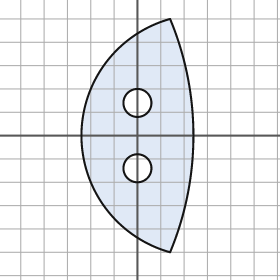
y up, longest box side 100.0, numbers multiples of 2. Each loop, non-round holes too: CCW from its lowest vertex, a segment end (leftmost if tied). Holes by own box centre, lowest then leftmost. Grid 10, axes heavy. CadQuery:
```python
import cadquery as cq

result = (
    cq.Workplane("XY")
    .moveTo(14.0, -50.0)
    .threePointArc((24.0, 0.0), (14.0, 50.0))
    .threePointArc((-24.0, 0.0), (14.0, -50.0))
    .close()
    .moveTo(0.0, -14.0)
    .circle(6.0)
    .moveTo(0.0, 14.0)
    .circle(6.0)
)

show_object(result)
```